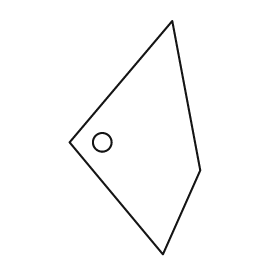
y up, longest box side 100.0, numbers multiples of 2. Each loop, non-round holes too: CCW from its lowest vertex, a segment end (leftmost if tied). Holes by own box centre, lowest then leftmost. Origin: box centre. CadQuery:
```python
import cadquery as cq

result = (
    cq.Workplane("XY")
    .moveTo(12.0, -50.0)
    .lineTo(28.0, -14.0)
    .lineTo(16.0, 50.0)
    .lineTo(-28.0, -2.0)
    .close()
    .moveTo(-14.0, -2.0)
    .circle(4.0)
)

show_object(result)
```